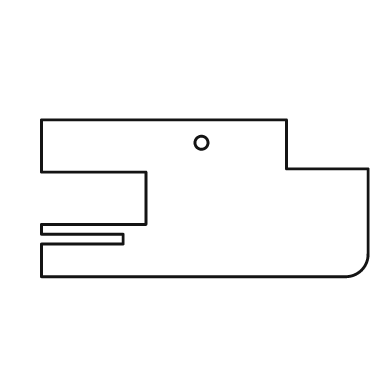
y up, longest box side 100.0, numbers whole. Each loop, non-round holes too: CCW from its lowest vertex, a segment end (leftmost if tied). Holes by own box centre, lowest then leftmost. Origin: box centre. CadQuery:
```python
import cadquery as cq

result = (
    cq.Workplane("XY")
    .moveTo(-50.0, -24.0)
    .lineTo(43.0, -24.0)
    .threePointArc((48.0, -22.0), (50.0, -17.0))
    .lineTo(50.0, 9.0)
    .lineTo(25.0, 9.0)
    .lineTo(25.0, 24.0)
    .lineTo(-50.0, 24.0)
    .lineTo(-50.0, 8.0)
    .lineTo(-18.0, 8.0)
    .lineTo(-18.0, -8.0)
    .lineTo(-50.0, -8.0)
    .lineTo(-50.0, -11.0)
    .lineTo(-25.0, -11.0)
    .lineTo(-25.0, -14.0)
    .lineTo(-50.0, -14.0)
    .close()
    .moveTo(-1.0, 17.0)
    .circle(2.0)
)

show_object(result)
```